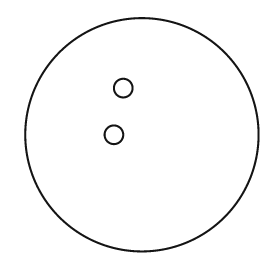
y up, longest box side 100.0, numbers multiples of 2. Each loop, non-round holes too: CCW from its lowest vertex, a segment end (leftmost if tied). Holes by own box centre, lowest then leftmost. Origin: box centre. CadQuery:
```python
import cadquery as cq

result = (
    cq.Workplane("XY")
    .moveTo(0.0, 0.0)
    .circle(50.0)
    .moveTo(-12.0, 0.0)
    .circle(4.0)
    .moveTo(-8.0, 20.0)
    .circle(4.0)
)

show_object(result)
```